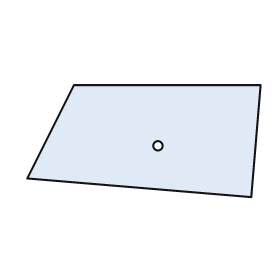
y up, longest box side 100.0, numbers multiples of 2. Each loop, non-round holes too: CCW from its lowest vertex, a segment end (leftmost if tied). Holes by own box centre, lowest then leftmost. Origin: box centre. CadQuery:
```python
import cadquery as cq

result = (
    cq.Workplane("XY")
    .moveTo(46.0, -24.0)
    .lineTo(50.0, 24.0)
    .lineTo(-30.0, 24.0)
    .lineTo(-50.0, -16.0)
    .close()
    .moveTo(6.0, -2.0)
    .circle(2.0)
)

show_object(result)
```